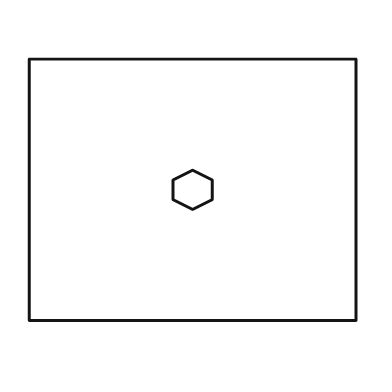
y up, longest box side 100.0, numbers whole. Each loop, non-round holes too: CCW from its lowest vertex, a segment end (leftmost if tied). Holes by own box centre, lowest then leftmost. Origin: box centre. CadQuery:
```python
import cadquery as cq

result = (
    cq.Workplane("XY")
    .moveTo(-50.0, -40.0)
    .lineTo(50.0, -40.0)
    .lineTo(50.0, 40.0)
    .lineTo(-50.0, 40.0)
    .close()
    .moveTo(0.0, -6.0)
    .lineTo(6.0, -3.0)
    .lineTo(6.0, 3.0)
    .lineTo(0.0, 6.0)
    .lineTo(-6.0, 3.0)
    .lineTo(-6.0, -3.0)
    .close()
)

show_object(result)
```